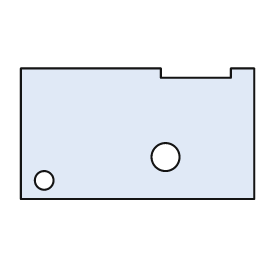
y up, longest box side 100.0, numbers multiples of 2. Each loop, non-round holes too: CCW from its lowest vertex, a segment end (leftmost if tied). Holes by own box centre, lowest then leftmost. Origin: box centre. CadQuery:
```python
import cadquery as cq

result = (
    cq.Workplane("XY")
    .moveTo(-50.0, -28.0)
    .lineTo(50.0, -28.0)
    .lineTo(50.0, 28.0)
    .lineTo(40.0, 28.0)
    .lineTo(40.0, 24.0)
    .lineTo(10.0, 24.0)
    .lineTo(10.0, 28.0)
    .lineTo(-50.0, 28.0)
    .close()
    .moveTo(-40.0, -20.0)
    .circle(4.0)
    .moveTo(12.0, -10.0)
    .circle(6.0)
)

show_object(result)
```